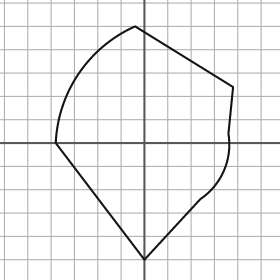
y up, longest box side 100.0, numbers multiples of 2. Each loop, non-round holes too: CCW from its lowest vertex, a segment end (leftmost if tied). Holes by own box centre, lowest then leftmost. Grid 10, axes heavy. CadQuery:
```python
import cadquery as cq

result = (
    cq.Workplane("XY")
    .moveTo(0.0, -50.0)
    .lineTo(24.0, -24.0)
    .threePointArc((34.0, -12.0), (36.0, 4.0))
    .lineTo(38.0, 24.0)
    .lineTo(-4.0, 50.0)
    .threePointArc((-28.0, 30.0), (-38.0, 0.0))
    .close()
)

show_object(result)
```